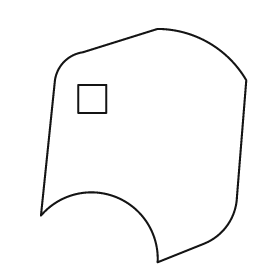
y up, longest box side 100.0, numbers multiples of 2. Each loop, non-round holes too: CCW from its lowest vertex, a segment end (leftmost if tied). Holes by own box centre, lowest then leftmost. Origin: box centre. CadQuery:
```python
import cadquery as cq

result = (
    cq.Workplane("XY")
    .moveTo(6.0, -50.0)
    .lineTo(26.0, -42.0)
    .threePointArc((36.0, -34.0), (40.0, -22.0))
    .lineTo(44.0, 28.0)
    .threePointArc((28.0, 44.0), (6.0, 50.0))
    .lineTo(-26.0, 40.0)
    .threePointArc((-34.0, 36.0), (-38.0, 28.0))
    .lineTo(-44.0, -30.0)
    .threePointArc((-12.0, -22.0), (6.0, -50.0))
    .close()
    .moveTo(-28.0, 14.0)
    .lineTo(-16.0, 14.0)
    .lineTo(-16.0, 26.0)
    .lineTo(-28.0, 26.0)
    .close()
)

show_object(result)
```